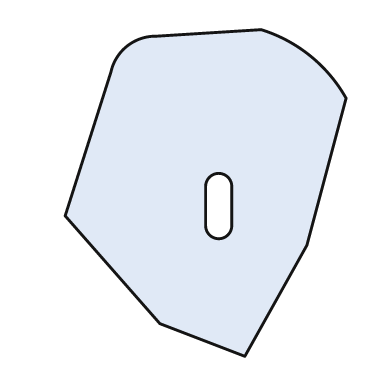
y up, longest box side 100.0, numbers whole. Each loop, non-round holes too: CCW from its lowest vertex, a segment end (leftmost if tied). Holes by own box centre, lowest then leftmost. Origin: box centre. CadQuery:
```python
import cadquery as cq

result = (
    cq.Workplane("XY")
    .moveTo(12.0, -50.0)
    .lineTo(31.0, -16.0)
    .lineTo(43.0, 29.0)
    .threePointArc((32.0, 42.0), (17.0, 50.0))
    .lineTo(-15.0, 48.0)
    .threePointArc((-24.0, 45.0), (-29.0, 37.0))
    .lineTo(-43.0, -7.0)
    .lineTo(-14.0, -40.0)
    .close()
    .moveTo(0.0, -10.0)
    .threePointArc((4.0, -14.0), (8.0, -10.0))
    .lineTo(8.0, 2.0)
    .threePointArc((4.0, 6.0), (0.0, 2.0))
    .close()
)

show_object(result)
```